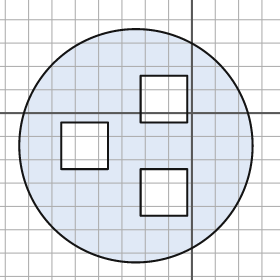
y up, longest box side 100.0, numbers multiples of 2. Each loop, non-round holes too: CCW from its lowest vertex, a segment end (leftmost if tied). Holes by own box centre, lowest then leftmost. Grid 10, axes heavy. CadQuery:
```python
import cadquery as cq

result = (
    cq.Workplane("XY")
    .moveTo(-24.0, -14.0)
    .circle(50.0)
    .moveTo(-22.0, -44.0)
    .lineTo(-2.0, -44.0)
    .lineTo(-2.0, -24.0)
    .lineTo(-22.0, -24.0)
    .close()
    .moveTo(-56.0, -24.0)
    .lineTo(-36.0, -24.0)
    .lineTo(-36.0, -4.0)
    .lineTo(-56.0, -4.0)
    .close()
    .moveTo(-22.0, -4.0)
    .lineTo(-2.0, -4.0)
    .lineTo(-2.0, 16.0)
    .lineTo(-22.0, 16.0)
    .close()
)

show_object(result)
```